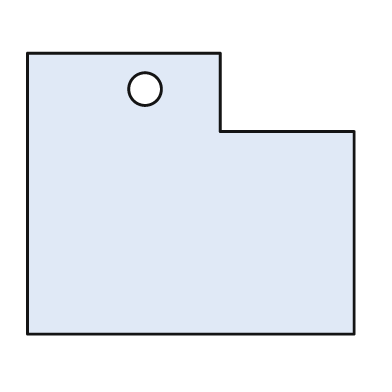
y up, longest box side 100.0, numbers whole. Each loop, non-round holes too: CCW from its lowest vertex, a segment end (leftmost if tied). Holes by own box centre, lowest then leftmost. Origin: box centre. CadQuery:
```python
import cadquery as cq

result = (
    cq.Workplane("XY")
    .moveTo(-50.0, -43.0)
    .lineTo(50.0, -43.0)
    .lineTo(50.0, 19.0)
    .lineTo(9.0, 19.0)
    .lineTo(9.0, 43.0)
    .lineTo(-50.0, 43.0)
    .close()
    .moveTo(-14.0, 32.0)
    .circle(5.0)
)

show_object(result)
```